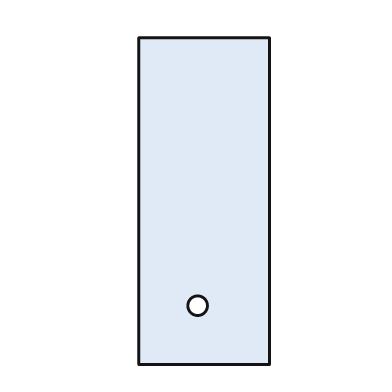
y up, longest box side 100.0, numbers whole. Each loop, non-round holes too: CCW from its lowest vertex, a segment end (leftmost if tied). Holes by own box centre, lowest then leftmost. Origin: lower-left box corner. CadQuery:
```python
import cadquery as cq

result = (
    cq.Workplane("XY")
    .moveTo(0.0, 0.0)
    .lineTo(40.0, 0.0)
    .lineTo(40.0, 100.0)
    .lineTo(0.0, 100.0)
    .close()
    .moveTo(18.0, 18.0)
    .circle(3.0)
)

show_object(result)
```